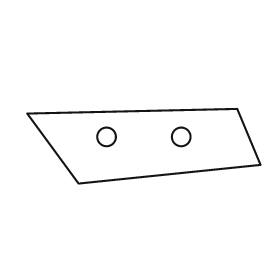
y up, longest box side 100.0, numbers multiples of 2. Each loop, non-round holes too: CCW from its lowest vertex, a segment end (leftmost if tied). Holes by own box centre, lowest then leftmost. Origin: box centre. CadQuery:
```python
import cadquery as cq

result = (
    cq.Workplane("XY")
    .moveTo(-28.0, -16.0)
    .lineTo(50.0, -8.0)
    .lineTo(40.0, 16.0)
    .lineTo(-50.0, 14.0)
    .close()
    .moveTo(-16.0, 4.0)
    .circle(4.0)
    .moveTo(16.0, 4.0)
    .circle(4.0)
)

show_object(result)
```